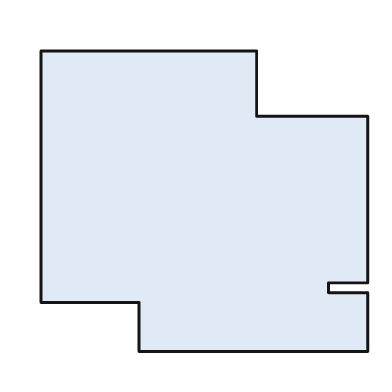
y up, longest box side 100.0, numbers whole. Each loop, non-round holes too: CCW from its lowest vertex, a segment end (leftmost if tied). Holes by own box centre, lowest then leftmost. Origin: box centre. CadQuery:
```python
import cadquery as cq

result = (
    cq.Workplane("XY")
    .moveTo(-20.0, -46.0)
    .lineTo(50.0, -46.0)
    .lineTo(50.0, -28.0)
    .lineTo(38.0, -28.0)
    .lineTo(38.0, -25.0)
    .lineTo(50.0, -25.0)
    .lineTo(50.0, 26.0)
    .lineTo(16.0, 26.0)
    .lineTo(16.0, 46.0)
    .lineTo(-50.0, 46.0)
    .lineTo(-50.0, -31.0)
    .lineTo(-20.0, -31.0)
    .close()
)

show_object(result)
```